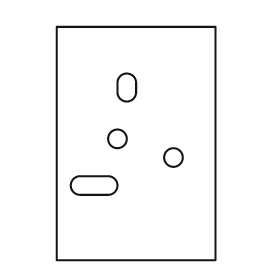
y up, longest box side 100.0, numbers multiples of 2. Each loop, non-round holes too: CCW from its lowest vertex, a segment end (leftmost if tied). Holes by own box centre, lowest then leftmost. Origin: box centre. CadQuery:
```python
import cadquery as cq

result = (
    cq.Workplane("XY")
    .moveTo(-34.0, -50.0)
    .lineTo(34.0, -50.0)
    .lineTo(34.0, 50.0)
    .lineTo(-34.0, 50.0)
    .close()
    .moveTo(-24.0, -22.0)
    .lineTo(-12.0, -22.0)
    .threePointArc((-8.0, -18.0), (-12.0, -14.0))
    .lineTo(-24.0, -14.0)
    .threePointArc((-28.0, -18.0), (-24.0, -22.0))
    .close()
    .moveTo(16.0, -6.0)
    .circle(4.0)
    .moveTo(-8.0, 2.0)
    .circle(4.0)
    .moveTo(-8.0, 22.0)
    .threePointArc((-4.0, 18.0), (0.0, 22.0))
    .lineTo(0.0, 26.0)
    .threePointArc((-4.0, 30.0), (-8.0, 26.0))
    .close()
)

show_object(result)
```